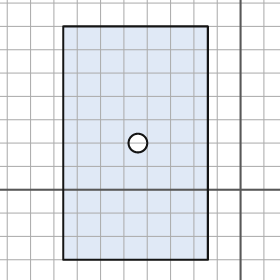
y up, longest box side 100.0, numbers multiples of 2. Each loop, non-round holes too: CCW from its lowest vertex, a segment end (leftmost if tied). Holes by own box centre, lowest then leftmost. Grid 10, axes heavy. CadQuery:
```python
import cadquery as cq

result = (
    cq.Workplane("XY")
    .moveTo(-76.0, -30.0)
    .lineTo(-14.0, -30.0)
    .lineTo(-14.0, 70.0)
    .lineTo(-76.0, 70.0)
    .close()
    .moveTo(-44.0, 20.0)
    .circle(4.0)
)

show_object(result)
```